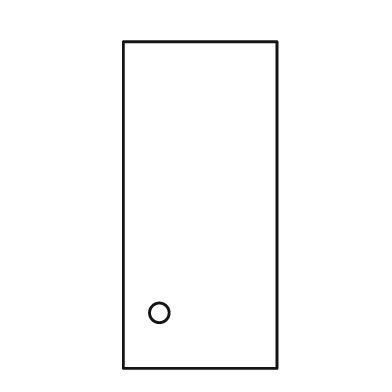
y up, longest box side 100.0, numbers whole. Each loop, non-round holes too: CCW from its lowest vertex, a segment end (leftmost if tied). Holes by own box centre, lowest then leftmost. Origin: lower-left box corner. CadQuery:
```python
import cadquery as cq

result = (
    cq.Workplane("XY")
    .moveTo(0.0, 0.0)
    .lineTo(47.0, 0.0)
    .lineTo(47.0, 100.0)
    .lineTo(0.0, 100.0)
    .close()
    .moveTo(11.0, 17.0)
    .circle(3.0)
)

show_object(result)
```